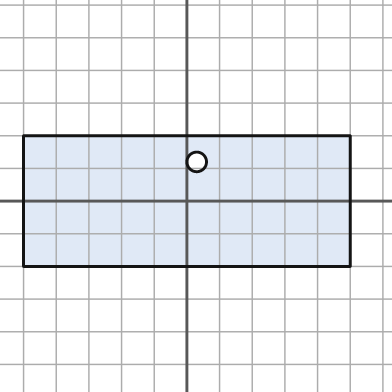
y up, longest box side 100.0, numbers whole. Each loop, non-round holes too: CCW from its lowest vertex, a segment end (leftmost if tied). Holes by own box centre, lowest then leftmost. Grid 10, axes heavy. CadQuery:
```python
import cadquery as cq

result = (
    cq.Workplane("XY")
    .moveTo(-50.0, -20.0)
    .lineTo(50.0, -20.0)
    .lineTo(50.0, 20.0)
    .lineTo(-50.0, 20.0)
    .close()
    .moveTo(3.0, 12.0)
    .circle(3.0)
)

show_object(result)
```